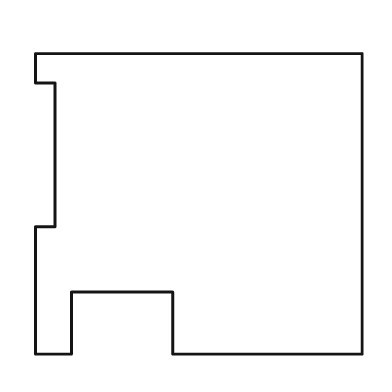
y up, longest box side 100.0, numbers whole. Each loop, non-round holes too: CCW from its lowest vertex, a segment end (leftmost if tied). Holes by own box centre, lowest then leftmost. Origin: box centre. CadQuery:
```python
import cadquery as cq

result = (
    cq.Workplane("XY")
    .moveTo(-50.0, -46.0)
    .lineTo(-39.0, -46.0)
    .lineTo(-39.0, -27.0)
    .lineTo(-8.0, -27.0)
    .lineTo(-8.0, -46.0)
    .lineTo(50.0, -46.0)
    .lineTo(50.0, 46.0)
    .lineTo(-50.0, 46.0)
    .lineTo(-50.0, 37.0)
    .lineTo(-44.0, 37.0)
    .lineTo(-44.0, -7.0)
    .lineTo(-50.0, -7.0)
    .close()
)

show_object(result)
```